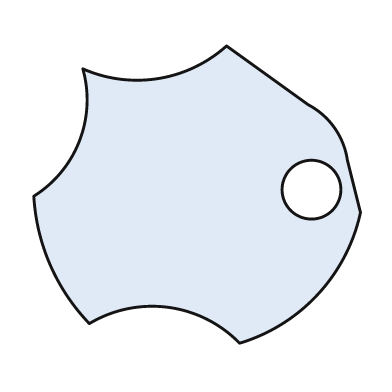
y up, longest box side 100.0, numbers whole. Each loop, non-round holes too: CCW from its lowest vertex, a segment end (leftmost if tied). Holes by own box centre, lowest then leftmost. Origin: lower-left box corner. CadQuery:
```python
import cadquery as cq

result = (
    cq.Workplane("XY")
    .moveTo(63.0, 0.0)
    .threePointArc((87.0, 15.0), (100.0, 40.0))
    .lineTo(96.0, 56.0)
    .threePointArc((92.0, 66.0), (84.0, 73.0))
    .lineTo(59.0, 91.0)
    .threePointArc((38.0, 81.0), (15.0, 84.0))
    .threePointArc((14.0, 62.0), (0.0, 45.0))
    .threePointArc((5.0, 24.0), (17.0, 6.0))
    .threePointArc((41.0, 11.0), (63.0, 0.0))
    .close()
    .moveTo(85.0, 47.0)
    .circle(9.0)
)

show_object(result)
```